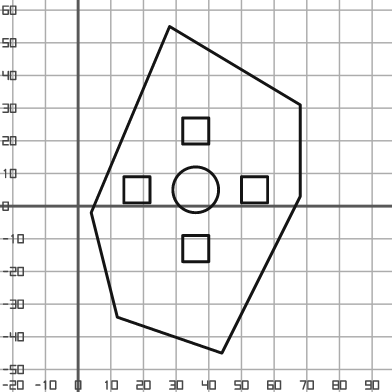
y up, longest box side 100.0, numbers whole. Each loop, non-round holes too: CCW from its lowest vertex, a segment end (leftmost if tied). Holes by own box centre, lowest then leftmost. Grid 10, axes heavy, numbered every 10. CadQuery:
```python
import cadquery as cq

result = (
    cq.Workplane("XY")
    .moveTo(44.0, -45.0)
    .lineTo(68.0, 3.0)
    .lineTo(68.0, 31.0)
    .lineTo(28.0, 55.0)
    .lineTo(4.0, -2.0)
    .lineTo(12.0, -34.0)
    .close()
    .moveTo(32.0, -17.0)
    .lineTo(40.0, -17.0)
    .lineTo(40.0, -9.0)
    .lineTo(32.0, -9.0)
    .close()
    .moveTo(14.0, 1.0)
    .lineTo(22.0, 1.0)
    .lineTo(22.0, 9.0)
    .lineTo(14.0, 9.0)
    .close()
    .moveTo(36.0, 5.0)
    .circle(7.0)
    .moveTo(50.0, 1.0)
    .lineTo(58.0, 1.0)
    .lineTo(58.0, 9.0)
    .lineTo(50.0, 9.0)
    .close()
    .moveTo(32.0, 19.0)
    .lineTo(40.0, 19.0)
    .lineTo(40.0, 27.0)
    .lineTo(32.0, 27.0)
    .close()
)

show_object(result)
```